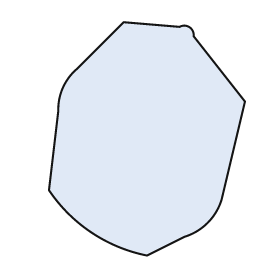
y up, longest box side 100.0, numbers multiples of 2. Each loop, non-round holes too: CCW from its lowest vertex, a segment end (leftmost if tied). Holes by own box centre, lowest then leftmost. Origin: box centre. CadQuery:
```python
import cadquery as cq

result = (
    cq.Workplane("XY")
    .moveTo(0.0, -50.0)
    .lineTo(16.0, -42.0)
    .threePointArc((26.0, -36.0), (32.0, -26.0))
    .lineTo(42.0, 16.0)
    .lineTo(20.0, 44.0)
    .threePointArc((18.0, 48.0), (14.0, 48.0))
    .lineTo(-10.0, 50.0)
    .lineTo(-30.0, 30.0)
    .threePointArc((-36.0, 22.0), (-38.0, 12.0))
    .lineTo(-42.0, -22.0)
    .threePointArc((-24.0, -40.0), (0.0, -50.0))
    .close()
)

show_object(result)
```